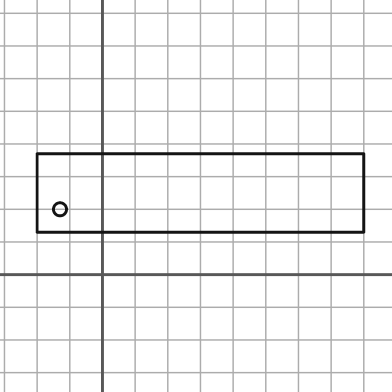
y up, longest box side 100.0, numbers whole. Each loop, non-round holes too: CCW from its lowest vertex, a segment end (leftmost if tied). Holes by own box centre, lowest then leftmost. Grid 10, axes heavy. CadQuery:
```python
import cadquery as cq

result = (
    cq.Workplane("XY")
    .moveTo(-20.0, 13.0)
    .lineTo(80.0, 13.0)
    .lineTo(80.0, 37.0)
    .lineTo(-20.0, 37.0)
    .close()
    .moveTo(-13.0, 20.0)
    .circle(2.0)
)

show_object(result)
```